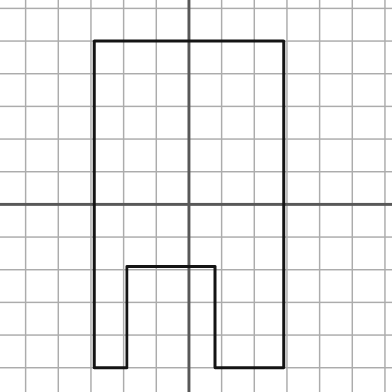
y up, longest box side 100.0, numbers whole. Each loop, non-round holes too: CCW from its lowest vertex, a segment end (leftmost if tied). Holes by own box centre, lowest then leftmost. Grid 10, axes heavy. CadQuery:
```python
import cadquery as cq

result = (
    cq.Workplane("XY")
    .moveTo(-29.0, -50.0)
    .lineTo(-19.0, -50.0)
    .lineTo(-19.0, -19.0)
    .lineTo(8.0, -19.0)
    .lineTo(8.0, -50.0)
    .lineTo(29.0, -50.0)
    .lineTo(29.0, 50.0)
    .lineTo(-29.0, 50.0)
    .close()
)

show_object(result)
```